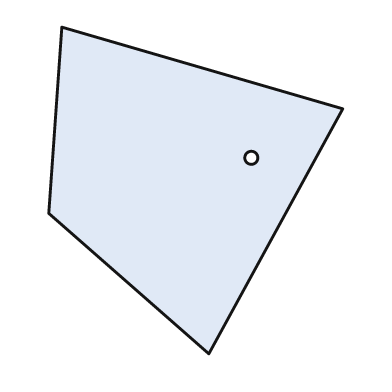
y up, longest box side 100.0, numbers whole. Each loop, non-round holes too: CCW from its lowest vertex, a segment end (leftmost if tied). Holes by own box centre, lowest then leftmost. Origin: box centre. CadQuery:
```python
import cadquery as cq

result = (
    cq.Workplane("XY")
    .moveTo(4.0, -50.0)
    .lineTo(45.0, 25.0)
    .lineTo(-41.0, 50.0)
    .lineTo(-45.0, -7.0)
    .close()
    .moveTo(17.0, 10.0)
    .circle(2.0)
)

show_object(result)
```